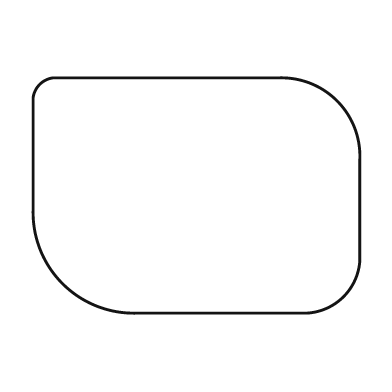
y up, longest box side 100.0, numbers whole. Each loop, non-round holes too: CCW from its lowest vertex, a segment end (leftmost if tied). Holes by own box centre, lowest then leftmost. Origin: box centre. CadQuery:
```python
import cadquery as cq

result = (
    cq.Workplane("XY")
    .moveTo(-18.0, -36.0)
    .lineTo(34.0, -36.0)
    .threePointArc((45.0, -31.0), (50.0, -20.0))
    .lineTo(50.0, 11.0)
    .threePointArc((43.0, 29.0), (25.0, 36.0))
    .lineTo(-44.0, 36.0)
    .threePointArc((-48.0, 34.0), (-50.0, 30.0))
    .lineTo(-50.0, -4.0)
    .threePointArc((-41.0, -27.0), (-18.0, -36.0))
    .close()
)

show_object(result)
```